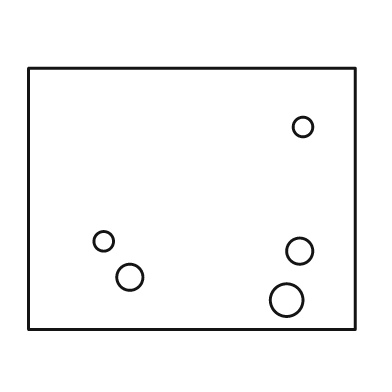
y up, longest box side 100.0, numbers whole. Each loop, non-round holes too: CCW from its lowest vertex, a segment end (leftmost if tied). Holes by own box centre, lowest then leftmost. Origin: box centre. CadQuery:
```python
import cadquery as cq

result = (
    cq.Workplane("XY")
    .moveTo(-50.0, -40.0)
    .lineTo(50.0, -40.0)
    .lineTo(50.0, 40.0)
    .lineTo(-50.0, 40.0)
    .close()
    .moveTo(29.0, -31.0)
    .circle(5.0)
    .moveTo(-19.0, -24.0)
    .circle(4.0)
    .moveTo(33.0, -16.0)
    .circle(4.0)
    .moveTo(-27.0, -13.0)
    .circle(3.0)
    .moveTo(34.0, 22.0)
    .circle(3.0)
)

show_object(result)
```